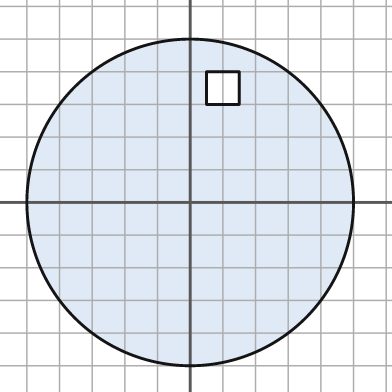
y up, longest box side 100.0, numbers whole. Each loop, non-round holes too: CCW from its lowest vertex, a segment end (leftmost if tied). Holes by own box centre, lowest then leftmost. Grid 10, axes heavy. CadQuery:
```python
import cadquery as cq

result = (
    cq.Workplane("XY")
    .moveTo(0.0, 0.0)
    .circle(50.0)
    .moveTo(5.0, 30.0)
    .lineTo(15.0, 30.0)
    .lineTo(15.0, 40.0)
    .lineTo(5.0, 40.0)
    .close()
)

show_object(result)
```